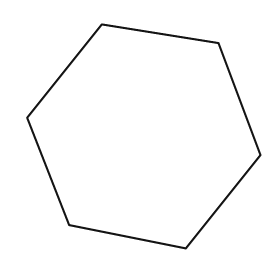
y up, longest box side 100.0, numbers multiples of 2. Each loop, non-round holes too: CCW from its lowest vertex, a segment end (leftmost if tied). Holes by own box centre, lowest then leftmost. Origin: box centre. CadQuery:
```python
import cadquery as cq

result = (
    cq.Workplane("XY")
    .moveTo(18.0, -48.0)
    .lineTo(50.0, -8.0)
    .lineTo(32.0, 40.0)
    .lineTo(-18.0, 48.0)
    .lineTo(-50.0, 8.0)
    .lineTo(-32.0, -38.0)
    .close()
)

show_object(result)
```